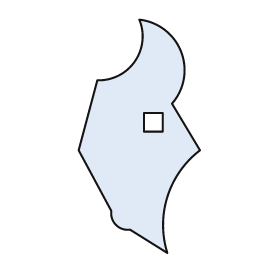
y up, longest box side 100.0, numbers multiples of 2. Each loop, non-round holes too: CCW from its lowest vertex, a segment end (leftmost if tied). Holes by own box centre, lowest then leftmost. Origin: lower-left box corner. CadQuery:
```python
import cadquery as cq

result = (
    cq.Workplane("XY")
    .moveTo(38.0, 0.0)
    .threePointArc((38.0, 24.0), (52.0, 44.0))
    .lineTo(40.0, 64.0)
    .threePointArc((44.0, 86.0), (26.0, 100.0))
    .threePointArc((24.0, 82.0), (8.0, 74.0))
    .lineTo(0.0, 44.0)
    .lineTo(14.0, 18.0)
    .threePointArc((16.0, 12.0), (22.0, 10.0))
    .close()
    .moveTo(28.0, 52.0)
    .lineTo(36.0, 52.0)
    .lineTo(36.0, 60.0)
    .lineTo(28.0, 60.0)
    .close()
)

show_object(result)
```